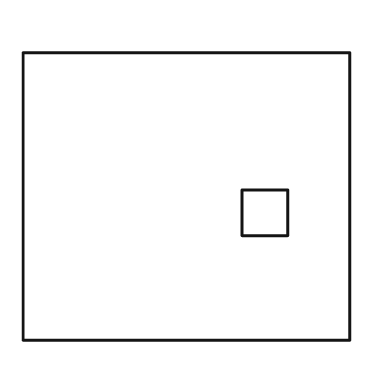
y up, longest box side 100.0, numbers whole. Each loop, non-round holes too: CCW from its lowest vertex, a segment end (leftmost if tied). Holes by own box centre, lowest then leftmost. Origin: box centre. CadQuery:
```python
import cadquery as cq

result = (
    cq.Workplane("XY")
    .moveTo(-50.0, -44.0)
    .lineTo(50.0, -44.0)
    .lineTo(50.0, 44.0)
    .lineTo(-50.0, 44.0)
    .close()
    .moveTo(17.0, -12.0)
    .lineTo(31.0, -12.0)
    .lineTo(31.0, 2.0)
    .lineTo(17.0, 2.0)
    .close()
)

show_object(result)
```